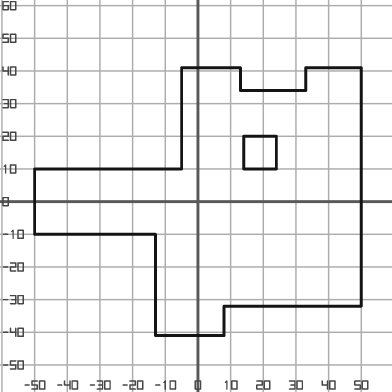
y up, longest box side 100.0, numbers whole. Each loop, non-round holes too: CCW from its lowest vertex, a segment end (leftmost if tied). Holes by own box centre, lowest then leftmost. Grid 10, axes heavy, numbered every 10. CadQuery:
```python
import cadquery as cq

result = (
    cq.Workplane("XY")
    .moveTo(-13.0, -41.0)
    .lineTo(8.0, -41.0)
    .lineTo(8.0, -32.0)
    .lineTo(50.0, -32.0)
    .lineTo(50.0, 41.0)
    .lineTo(33.0, 41.0)
    .lineTo(33.0, 34.0)
    .lineTo(13.0, 34.0)
    .lineTo(13.0, 41.0)
    .lineTo(-5.0, 41.0)
    .lineTo(-5.0, 10.0)
    .lineTo(-50.0, 10.0)
    .lineTo(-50.0, -10.0)
    .lineTo(-13.0, -10.0)
    .close()
    .moveTo(14.0, 10.0)
    .lineTo(24.0, 10.0)
    .lineTo(24.0, 20.0)
    .lineTo(14.0, 20.0)
    .close()
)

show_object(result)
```